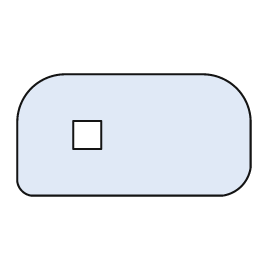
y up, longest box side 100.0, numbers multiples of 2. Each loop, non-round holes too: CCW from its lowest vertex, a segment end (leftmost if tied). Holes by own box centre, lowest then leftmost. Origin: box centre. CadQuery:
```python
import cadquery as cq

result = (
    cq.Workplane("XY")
    .moveTo(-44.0, -26.0)
    .lineTo(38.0, -26.0)
    .threePointArc((46.0, -22.0), (50.0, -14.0))
    .lineTo(50.0, 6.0)
    .threePointArc((44.0, 20.0), (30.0, 26.0))
    .lineTo(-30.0, 26.0)
    .threePointArc((-44.0, 20.0), (-50.0, 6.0))
    .lineTo(-50.0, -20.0)
    .threePointArc((-48.0, -24.0), (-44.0, -26.0))
    .close()
    .moveTo(-26.0, -6.0)
    .lineTo(-14.0, -6.0)
    .lineTo(-14.0, 6.0)
    .lineTo(-26.0, 6.0)
    .close()
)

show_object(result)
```